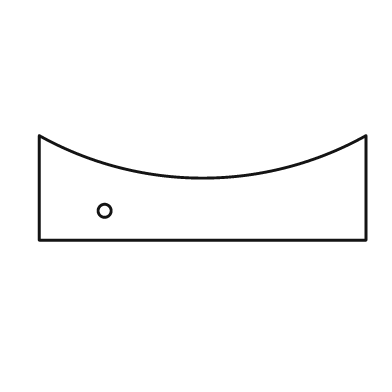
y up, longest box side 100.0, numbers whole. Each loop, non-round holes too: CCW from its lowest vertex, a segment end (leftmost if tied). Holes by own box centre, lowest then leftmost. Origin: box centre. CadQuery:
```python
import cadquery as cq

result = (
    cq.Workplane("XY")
    .moveTo(-50.0, -16.0)
    .lineTo(50.0, -16.0)
    .lineTo(50.0, 16.0)
    .threePointArc((0.0, 3.0), (-50.0, 16.0))
    .close()
    .moveTo(-30.0, -7.0)
    .circle(2.0)
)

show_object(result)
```